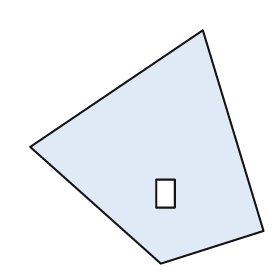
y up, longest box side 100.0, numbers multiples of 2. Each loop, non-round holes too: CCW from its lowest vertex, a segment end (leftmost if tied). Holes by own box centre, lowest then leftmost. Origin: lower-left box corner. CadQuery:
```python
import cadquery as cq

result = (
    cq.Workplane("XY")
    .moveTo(56.0, 0.0)
    .lineTo(100.0, 14.0)
    .lineTo(74.0, 100.0)
    .lineTo(0.0, 50.0)
    .close()
    .moveTo(54.0, 24.0)
    .lineTo(62.0, 24.0)
    .lineTo(62.0, 36.0)
    .lineTo(54.0, 36.0)
    .close()
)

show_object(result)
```